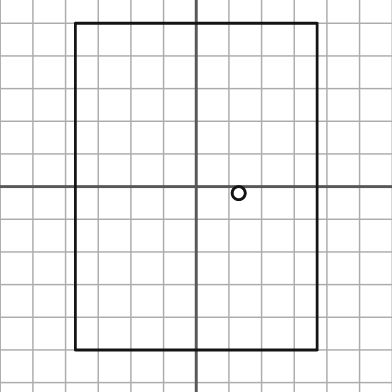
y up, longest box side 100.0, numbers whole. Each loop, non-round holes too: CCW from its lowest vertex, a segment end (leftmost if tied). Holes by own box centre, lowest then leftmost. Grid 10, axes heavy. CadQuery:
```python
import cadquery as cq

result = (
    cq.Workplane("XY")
    .moveTo(-37.0, -50.0)
    .lineTo(37.0, -50.0)
    .lineTo(37.0, 50.0)
    .lineTo(-37.0, 50.0)
    .close()
    .moveTo(13.0, -2.0)
    .circle(2.0)
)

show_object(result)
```